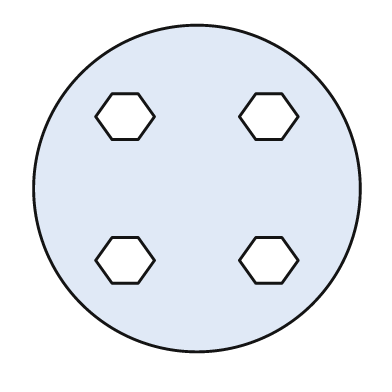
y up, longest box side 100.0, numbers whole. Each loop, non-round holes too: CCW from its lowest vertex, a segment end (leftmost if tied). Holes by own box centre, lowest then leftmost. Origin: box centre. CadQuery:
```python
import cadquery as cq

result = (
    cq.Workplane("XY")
    .moveTo(0.0, 0.0)
    .circle(50.0)
    .moveTo(-26.0, -29.0)
    .lineTo(-18.0, -29.0)
    .lineTo(-13.0, -22.0)
    .lineTo(-18.0, -15.0)
    .lineTo(-26.0, -15.0)
    .lineTo(-31.0, -22.0)
    .close()
    .moveTo(18.0, -29.0)
    .lineTo(26.0, -29.0)
    .lineTo(31.0, -22.0)
    .lineTo(26.0, -15.0)
    .lineTo(18.0, -15.0)
    .lineTo(13.0, -22.0)
    .close()
    .moveTo(-26.0, 15.0)
    .lineTo(-18.0, 15.0)
    .lineTo(-13.0, 22.0)
    .lineTo(-18.0, 29.0)
    .lineTo(-26.0, 29.0)
    .lineTo(-31.0, 22.0)
    .close()
    .moveTo(18.0, 15.0)
    .lineTo(26.0, 15.0)
    .lineTo(31.0, 22.0)
    .lineTo(26.0, 29.0)
    .lineTo(18.0, 29.0)
    .lineTo(13.0, 22.0)
    .close()
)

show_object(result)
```